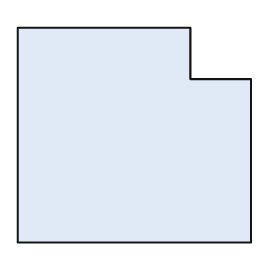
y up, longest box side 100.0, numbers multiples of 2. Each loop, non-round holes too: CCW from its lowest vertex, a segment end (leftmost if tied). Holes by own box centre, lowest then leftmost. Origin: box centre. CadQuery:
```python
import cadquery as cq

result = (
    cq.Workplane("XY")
    .moveTo(-50.0, -46.0)
    .lineTo(50.0, -46.0)
    .lineTo(50.0, 24.0)
    .lineTo(24.0, 24.0)
    .lineTo(24.0, 46.0)
    .lineTo(-50.0, 46.0)
    .close()
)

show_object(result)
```